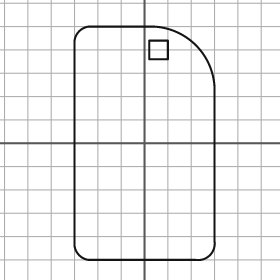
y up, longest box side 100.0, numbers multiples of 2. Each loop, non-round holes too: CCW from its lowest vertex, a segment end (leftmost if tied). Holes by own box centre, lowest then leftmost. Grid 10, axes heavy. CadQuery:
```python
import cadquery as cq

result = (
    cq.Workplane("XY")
    .moveTo(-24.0, -50.0)
    .lineTo(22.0, -50.0)
    .threePointArc((28.0, -48.0), (30.0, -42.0))
    .lineTo(30.0, 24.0)
    .threePointArc((22.0, 42.0), (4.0, 50.0))
    .lineTo(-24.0, 50.0)
    .threePointArc((-28.0, 48.0), (-30.0, 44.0))
    .lineTo(-30.0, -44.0)
    .threePointArc((-28.0, -48.0), (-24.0, -50.0))
    .close()
    .moveTo(2.0, 36.0)
    .lineTo(10.0, 36.0)
    .lineTo(10.0, 44.0)
    .lineTo(2.0, 44.0)
    .close()
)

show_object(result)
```